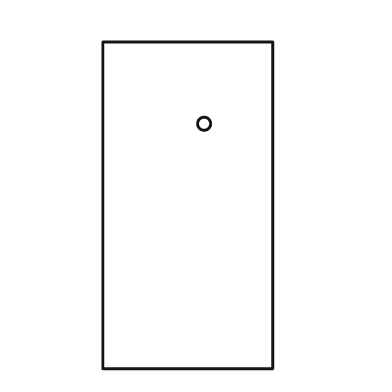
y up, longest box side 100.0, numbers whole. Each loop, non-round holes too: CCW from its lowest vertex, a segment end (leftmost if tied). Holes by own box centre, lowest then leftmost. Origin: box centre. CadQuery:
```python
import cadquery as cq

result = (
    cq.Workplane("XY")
    .moveTo(-26.0, -50.0)
    .lineTo(26.0, -50.0)
    .lineTo(26.0, 50.0)
    .lineTo(-26.0, 50.0)
    .close()
    .moveTo(5.0, 25.0)
    .circle(2.0)
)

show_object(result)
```